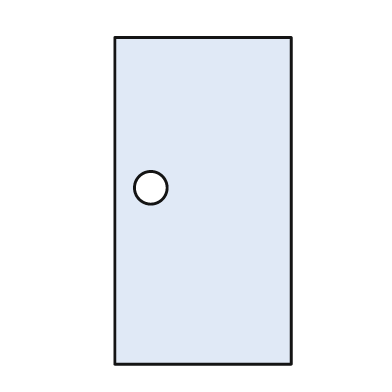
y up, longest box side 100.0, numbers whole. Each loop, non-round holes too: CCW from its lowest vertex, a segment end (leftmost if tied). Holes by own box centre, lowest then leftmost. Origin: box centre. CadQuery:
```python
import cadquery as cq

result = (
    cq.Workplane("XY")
    .moveTo(-27.0, -50.0)
    .lineTo(27.0, -50.0)
    .lineTo(27.0, 50.0)
    .lineTo(-27.0, 50.0)
    .close()
    .moveTo(-16.0, 4.0)
    .circle(5.0)
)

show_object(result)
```